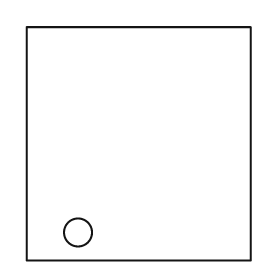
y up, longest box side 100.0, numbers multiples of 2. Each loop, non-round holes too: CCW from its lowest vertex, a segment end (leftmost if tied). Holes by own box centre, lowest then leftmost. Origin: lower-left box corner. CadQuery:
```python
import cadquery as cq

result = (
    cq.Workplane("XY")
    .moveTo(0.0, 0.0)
    .lineTo(96.0, 0.0)
    .lineTo(96.0, 100.0)
    .lineTo(0.0, 100.0)
    .close()
    .moveTo(22.0, 12.0)
    .circle(6.0)
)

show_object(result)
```